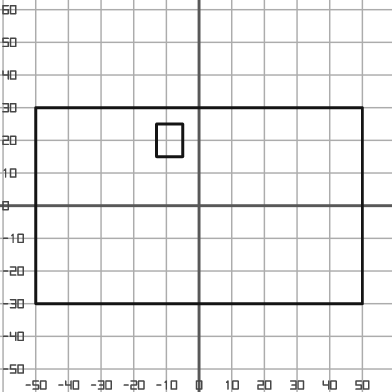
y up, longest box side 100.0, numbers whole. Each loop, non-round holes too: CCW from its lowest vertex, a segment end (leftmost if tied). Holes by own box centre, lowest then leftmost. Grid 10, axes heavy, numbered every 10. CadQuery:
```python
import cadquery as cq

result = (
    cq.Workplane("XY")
    .moveTo(-50.0, -30.0)
    .lineTo(50.0, -30.0)
    .lineTo(50.0, 30.0)
    .lineTo(-50.0, 30.0)
    .close()
    .moveTo(-13.0, 15.0)
    .lineTo(-5.0, 15.0)
    .lineTo(-5.0, 25.0)
    .lineTo(-13.0, 25.0)
    .close()
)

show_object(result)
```